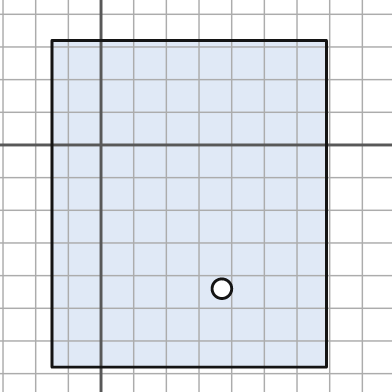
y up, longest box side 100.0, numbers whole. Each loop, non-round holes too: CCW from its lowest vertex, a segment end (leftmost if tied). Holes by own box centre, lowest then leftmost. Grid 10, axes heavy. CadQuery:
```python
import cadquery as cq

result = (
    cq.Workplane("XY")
    .moveTo(-15.0, -68.0)
    .lineTo(69.0, -68.0)
    .lineTo(69.0, 32.0)
    .lineTo(-15.0, 32.0)
    .close()
    .moveTo(37.0, -44.0)
    .circle(3.0)
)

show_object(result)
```